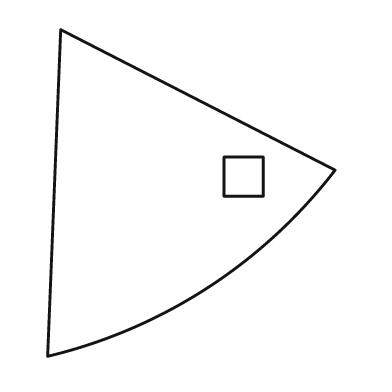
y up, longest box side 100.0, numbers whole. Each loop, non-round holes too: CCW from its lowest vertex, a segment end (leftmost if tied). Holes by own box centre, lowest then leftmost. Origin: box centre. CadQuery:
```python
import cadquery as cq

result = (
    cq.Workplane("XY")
    .moveTo(-44.0, -50.0)
    .threePointArc((5.0, -29.0), (44.0, 7.0))
    .lineTo(-40.0, 50.0)
    .close()
    .moveTo(10.0, -1.0)
    .lineTo(22.0, -1.0)
    .lineTo(22.0, 11.0)
    .lineTo(10.0, 11.0)
    .close()
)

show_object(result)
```